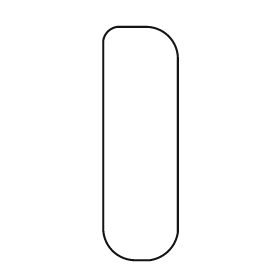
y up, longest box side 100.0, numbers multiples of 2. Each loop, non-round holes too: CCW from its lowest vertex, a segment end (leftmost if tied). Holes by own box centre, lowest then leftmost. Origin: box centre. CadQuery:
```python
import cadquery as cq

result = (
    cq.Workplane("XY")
    .moveTo(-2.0, -50.0)
    .lineTo(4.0, -50.0)
    .threePointArc((12.0, -46.0), (16.0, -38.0))
    .lineTo(16.0, 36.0)
    .threePointArc((12.0, 46.0), (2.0, 50.0))
    .lineTo(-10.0, 50.0)
    .threePointArc((-14.0, 48.0), (-16.0, 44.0))
    .lineTo(-16.0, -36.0)
    .threePointArc((-12.0, -46.0), (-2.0, -50.0))
    .close()
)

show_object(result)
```